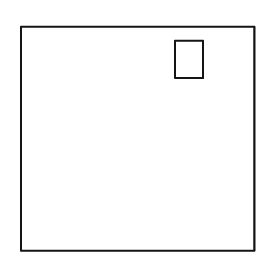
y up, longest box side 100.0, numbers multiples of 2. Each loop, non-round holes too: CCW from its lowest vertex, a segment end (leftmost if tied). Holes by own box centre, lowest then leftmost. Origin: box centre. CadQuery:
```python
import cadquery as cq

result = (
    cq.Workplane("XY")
    .moveTo(-50.0, -48.0)
    .lineTo(50.0, -48.0)
    .lineTo(50.0, 48.0)
    .lineTo(-50.0, 48.0)
    .close()
    .moveTo(16.0, 26.0)
    .lineTo(28.0, 26.0)
    .lineTo(28.0, 42.0)
    .lineTo(16.0, 42.0)
    .close()
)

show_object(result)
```